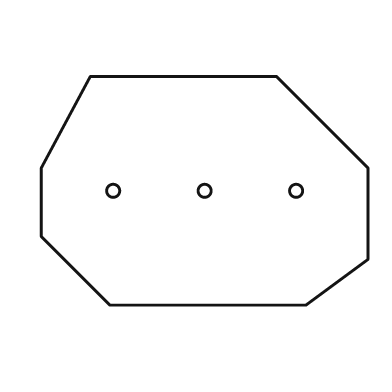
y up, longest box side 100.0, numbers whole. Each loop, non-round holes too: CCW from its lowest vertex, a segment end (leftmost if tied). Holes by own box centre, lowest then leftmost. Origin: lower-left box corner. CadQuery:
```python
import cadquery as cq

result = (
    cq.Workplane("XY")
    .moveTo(21.0, 0.0)
    .lineTo(81.0, 0.0)
    .lineTo(100.0, 14.0)
    .lineTo(100.0, 42.0)
    .lineTo(72.0, 70.0)
    .lineTo(15.0, 70.0)
    .lineTo(0.0, 42.0)
    .lineTo(0.0, 21.0)
    .close()
    .moveTo(22.0, 35.0)
    .circle(2.0)
    .moveTo(50.0, 35.0)
    .circle(2.0)
    .moveTo(78.0, 35.0)
    .circle(2.0)
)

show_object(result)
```